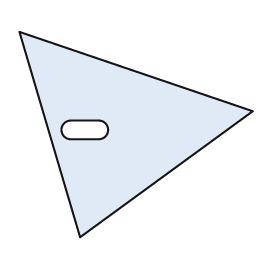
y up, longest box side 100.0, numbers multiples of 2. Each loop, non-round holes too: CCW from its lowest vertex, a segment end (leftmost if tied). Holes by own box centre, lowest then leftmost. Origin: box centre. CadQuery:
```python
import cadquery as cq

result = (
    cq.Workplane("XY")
    .moveTo(-24.0, -44.0)
    .lineTo(50.0, 10.0)
    .lineTo(-50.0, 44.0)
    .close()
    .moveTo(-28.0, -2.0)
    .lineTo(-16.0, -2.0)
    .threePointArc((-12.0, 2.0), (-16.0, 6.0))
    .lineTo(-28.0, 6.0)
    .threePointArc((-32.0, 2.0), (-28.0, -2.0))
    .close()
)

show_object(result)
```